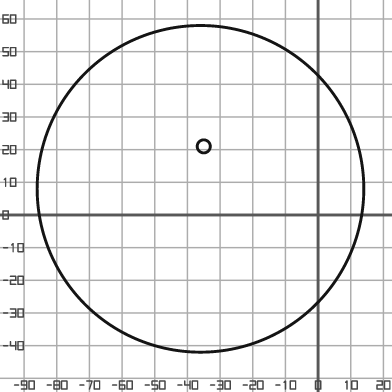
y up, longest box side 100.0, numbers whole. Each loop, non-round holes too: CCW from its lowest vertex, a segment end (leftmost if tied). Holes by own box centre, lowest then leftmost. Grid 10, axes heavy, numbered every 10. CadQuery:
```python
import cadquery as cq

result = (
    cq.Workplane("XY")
    .moveTo(-36.0, 8.0)
    .circle(50.0)
    .moveTo(-35.0, 21.0)
    .circle(2.0)
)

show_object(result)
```